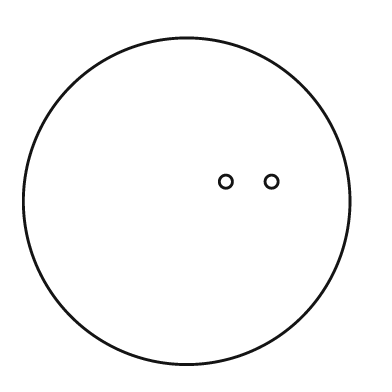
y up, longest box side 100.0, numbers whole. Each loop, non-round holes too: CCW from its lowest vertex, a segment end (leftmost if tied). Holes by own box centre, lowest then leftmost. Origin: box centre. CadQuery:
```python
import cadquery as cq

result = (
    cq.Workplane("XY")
    .moveTo(0.0, 0.0)
    .circle(50.0)
    .moveTo(12.0, 6.0)
    .circle(2.0)
    .moveTo(26.0, 6.0)
    .circle(2.0)
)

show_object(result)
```